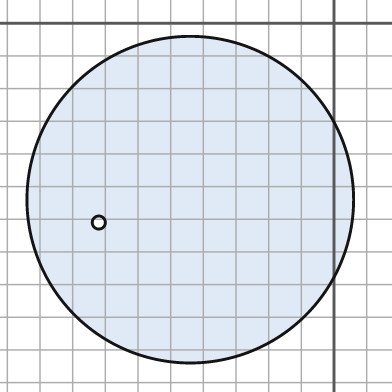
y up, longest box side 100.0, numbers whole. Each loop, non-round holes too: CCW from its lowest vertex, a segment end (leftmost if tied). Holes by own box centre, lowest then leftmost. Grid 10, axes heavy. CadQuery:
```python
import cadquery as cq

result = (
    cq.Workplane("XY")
    .moveTo(-44.0, -54.0)
    .circle(50.0)
    .moveTo(-72.0, -61.0)
    .circle(2.0)
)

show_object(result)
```